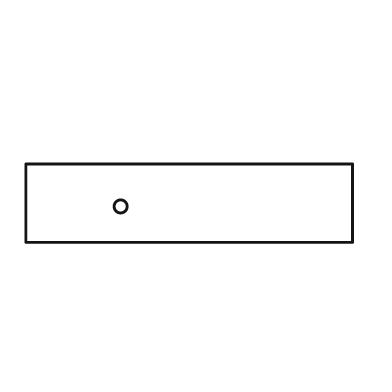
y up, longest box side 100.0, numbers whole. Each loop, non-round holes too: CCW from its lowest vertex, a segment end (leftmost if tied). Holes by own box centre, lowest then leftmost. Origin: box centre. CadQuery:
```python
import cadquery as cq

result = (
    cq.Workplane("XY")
    .moveTo(-50.0, -12.0)
    .lineTo(50.0, -12.0)
    .lineTo(50.0, 12.0)
    .lineTo(-50.0, 12.0)
    .close()
    .moveTo(-21.0, -1.0)
    .circle(2.0)
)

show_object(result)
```